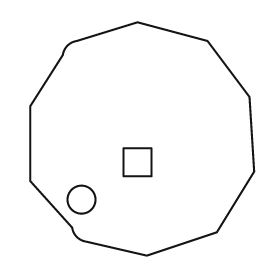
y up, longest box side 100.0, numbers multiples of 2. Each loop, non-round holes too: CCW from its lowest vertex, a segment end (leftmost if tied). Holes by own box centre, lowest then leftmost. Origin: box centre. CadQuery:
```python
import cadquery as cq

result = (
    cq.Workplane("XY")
    .moveTo(2.0, -50.0)
    .lineTo(32.0, -40.0)
    .lineTo(48.0, -14.0)
    .lineTo(46.0, 18.0)
    .lineTo(28.0, 42.0)
    .lineTo(-2.0, 50.0)
    .lineTo(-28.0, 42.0)
    .threePointArc((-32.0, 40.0), (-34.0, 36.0))
    .lineTo(-48.0, 14.0)
    .lineTo(-48.0, -18.0)
    .lineTo(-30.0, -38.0)
    .threePointArc((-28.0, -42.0), (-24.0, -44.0))
    .close()
    .moveTo(-26.0, -26.0)
    .circle(6.0)
    .moveTo(-8.0, -16.0)
    .lineTo(4.0, -16.0)
    .lineTo(4.0, -4.0)
    .lineTo(-8.0, -4.0)
    .close()
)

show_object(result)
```